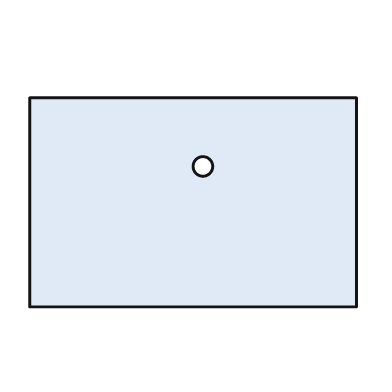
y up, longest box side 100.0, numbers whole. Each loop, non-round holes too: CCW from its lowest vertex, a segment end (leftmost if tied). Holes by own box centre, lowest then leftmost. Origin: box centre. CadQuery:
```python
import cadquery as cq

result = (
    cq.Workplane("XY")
    .moveTo(-50.0, -32.0)
    .lineTo(50.0, -32.0)
    .lineTo(50.0, 32.0)
    .lineTo(-50.0, 32.0)
    .close()
    .moveTo(3.0, 11.0)
    .circle(3.0)
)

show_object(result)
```